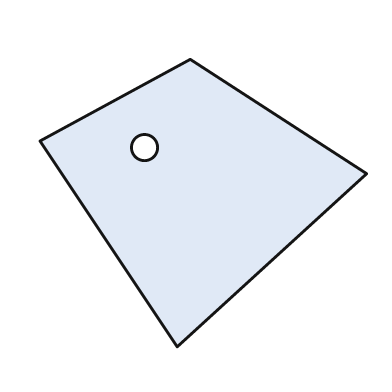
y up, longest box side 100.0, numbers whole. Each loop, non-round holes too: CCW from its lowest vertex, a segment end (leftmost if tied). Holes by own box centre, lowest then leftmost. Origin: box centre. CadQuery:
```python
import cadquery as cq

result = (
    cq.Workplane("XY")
    .moveTo(-8.0, -44.0)
    .lineTo(50.0, 9.0)
    .lineTo(-4.0, 44.0)
    .lineTo(-50.0, 19.0)
    .close()
    .moveTo(-18.0, 17.0)
    .circle(4.0)
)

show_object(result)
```